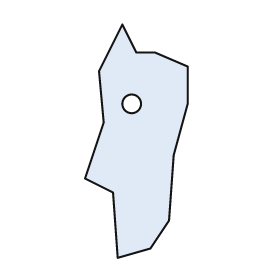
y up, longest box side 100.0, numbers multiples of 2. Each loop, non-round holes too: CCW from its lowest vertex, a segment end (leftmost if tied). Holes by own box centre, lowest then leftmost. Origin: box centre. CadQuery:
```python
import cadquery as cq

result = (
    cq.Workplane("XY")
    .moveTo(-8.0, -50.0)
    .lineTo(6.0, -46.0)
    .lineTo(14.0, -34.0)
    .lineTo(16.0, -6.0)
    .lineTo(22.0, 16.0)
    .lineTo(22.0, 32.0)
    .lineTo(8.0, 38.0)
    .lineTo(0.0, 38.0)
    .lineTo(-6.0, 50.0)
    .lineTo(-16.0, 30.0)
    .lineTo(-14.0, 8.0)
    .lineTo(-22.0, -16.0)
    .lineTo(-10.0, -22.0)
    .close()
    .moveTo(-2.0, 16.0)
    .circle(4.0)
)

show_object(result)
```